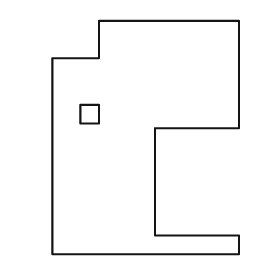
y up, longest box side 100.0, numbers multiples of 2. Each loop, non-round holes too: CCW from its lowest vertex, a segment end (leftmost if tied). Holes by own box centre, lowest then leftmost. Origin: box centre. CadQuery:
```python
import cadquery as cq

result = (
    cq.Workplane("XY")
    .moveTo(-40.0, -50.0)
    .lineTo(40.0, -50.0)
    .lineTo(40.0, -42.0)
    .lineTo(4.0, -42.0)
    .lineTo(4.0, 4.0)
    .lineTo(40.0, 4.0)
    .lineTo(40.0, 50.0)
    .lineTo(-20.0, 50.0)
    .lineTo(-20.0, 34.0)
    .lineTo(-40.0, 34.0)
    .close()
    .moveTo(-28.0, 6.0)
    .lineTo(-20.0, 6.0)
    .lineTo(-20.0, 14.0)
    .lineTo(-28.0, 14.0)
    .close()
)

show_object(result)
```